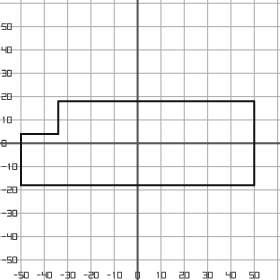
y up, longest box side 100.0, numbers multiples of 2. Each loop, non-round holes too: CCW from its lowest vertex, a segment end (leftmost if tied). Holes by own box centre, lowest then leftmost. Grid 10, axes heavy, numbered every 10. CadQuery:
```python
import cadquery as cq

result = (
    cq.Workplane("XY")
    .moveTo(-50.0, -18.0)
    .lineTo(50.0, -18.0)
    .lineTo(50.0, 18.0)
    .lineTo(-34.0, 18.0)
    .lineTo(-34.0, 4.0)
    .lineTo(-50.0, 4.0)
    .close()
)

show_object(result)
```